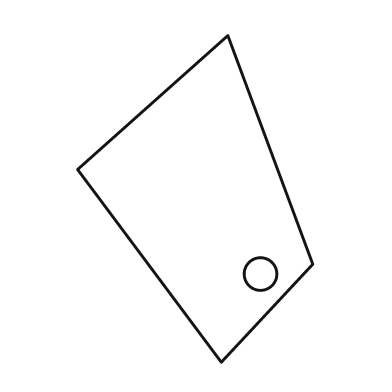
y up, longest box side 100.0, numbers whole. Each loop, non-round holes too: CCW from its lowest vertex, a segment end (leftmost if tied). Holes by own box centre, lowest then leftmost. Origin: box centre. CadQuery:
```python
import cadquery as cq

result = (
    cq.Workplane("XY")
    .moveTo(8.0, -50.0)
    .lineTo(36.0, -20.0)
    .lineTo(10.0, 50.0)
    .lineTo(-36.0, 9.0)
    .close()
    .moveTo(20.0, -23.0)
    .circle(5.0)
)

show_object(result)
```